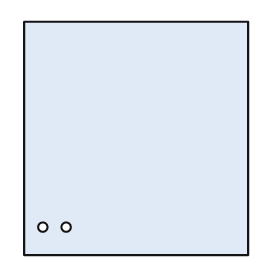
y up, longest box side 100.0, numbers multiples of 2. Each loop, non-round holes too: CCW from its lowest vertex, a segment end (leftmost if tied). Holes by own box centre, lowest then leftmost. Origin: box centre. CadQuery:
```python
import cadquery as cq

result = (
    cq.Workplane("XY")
    .moveTo(-48.0, -50.0)
    .lineTo(48.0, -50.0)
    .lineTo(48.0, 50.0)
    .lineTo(-48.0, 50.0)
    .close()
    .moveTo(-40.0, -38.0)
    .circle(2.0)
    .moveTo(-30.0, -38.0)
    .circle(2.0)
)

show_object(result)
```